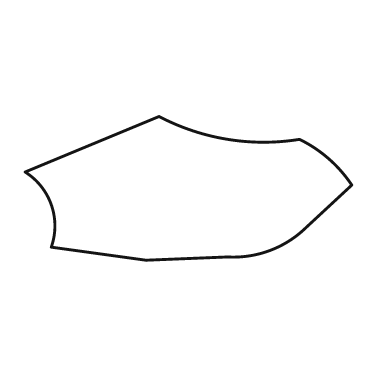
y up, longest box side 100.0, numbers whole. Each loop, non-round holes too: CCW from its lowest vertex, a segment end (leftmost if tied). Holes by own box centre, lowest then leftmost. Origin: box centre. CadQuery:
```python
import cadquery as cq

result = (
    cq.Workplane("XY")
    .moveTo(-13.0, -22.0)
    .lineTo(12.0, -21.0)
    .threePointArc((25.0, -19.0), (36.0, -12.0))
    .lineTo(50.0, 1.0)
    .threePointArc((43.0, 9.0), (34.0, 15.0))
    .threePointArc((12.0, 15.0), (-9.0, 22.0))
    .lineTo(-50.0, 5.0)
    .threePointArc((-42.0, -5.0), (-42.0, -18.0))
    .close()
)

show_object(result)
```